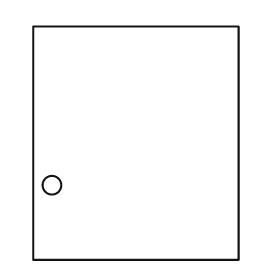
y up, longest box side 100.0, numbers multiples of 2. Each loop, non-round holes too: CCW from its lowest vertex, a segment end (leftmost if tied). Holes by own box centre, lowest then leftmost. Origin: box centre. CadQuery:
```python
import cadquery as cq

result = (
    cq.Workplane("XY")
    .moveTo(-44.0, -50.0)
    .lineTo(44.0, -50.0)
    .lineTo(44.0, 50.0)
    .lineTo(-44.0, 50.0)
    .close()
    .moveTo(-36.0, -18.0)
    .circle(4.0)
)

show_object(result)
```